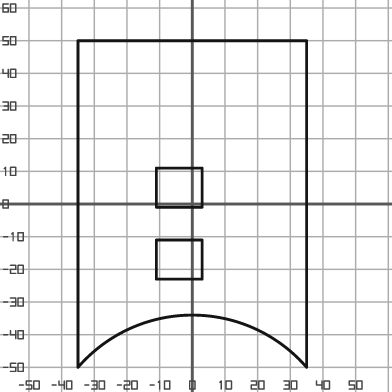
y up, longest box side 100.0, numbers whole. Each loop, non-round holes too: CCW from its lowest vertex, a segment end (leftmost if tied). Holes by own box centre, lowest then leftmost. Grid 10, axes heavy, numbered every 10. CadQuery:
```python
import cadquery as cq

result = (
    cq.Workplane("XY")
    .moveTo(-35.0, -50.0)
    .threePointArc((0.0, -34.0), (35.0, -50.0))
    .lineTo(35.0, 50.0)
    .lineTo(-35.0, 50.0)
    .close()
    .moveTo(-11.0, -23.0)
    .lineTo(3.0, -23.0)
    .lineTo(3.0, -11.0)
    .lineTo(-11.0, -11.0)
    .close()
    .moveTo(-11.0, -1.0)
    .lineTo(3.0, -1.0)
    .lineTo(3.0, 11.0)
    .lineTo(-11.0, 11.0)
    .close()
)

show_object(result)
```